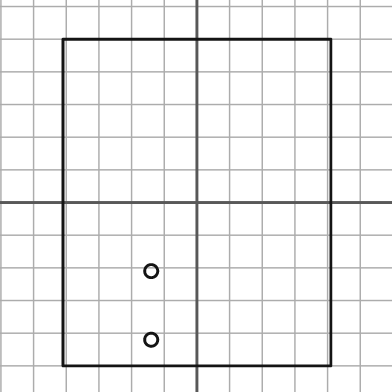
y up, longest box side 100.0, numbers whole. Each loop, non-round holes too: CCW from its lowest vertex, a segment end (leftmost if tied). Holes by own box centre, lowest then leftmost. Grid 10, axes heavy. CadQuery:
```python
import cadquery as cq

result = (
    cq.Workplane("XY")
    .moveTo(-41.0, -50.0)
    .lineTo(41.0, -50.0)
    .lineTo(41.0, 50.0)
    .lineTo(-41.0, 50.0)
    .close()
    .moveTo(-14.0, -42.0)
    .circle(2.0)
    .moveTo(-14.0, -21.0)
    .circle(2.0)
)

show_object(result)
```